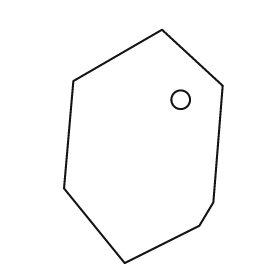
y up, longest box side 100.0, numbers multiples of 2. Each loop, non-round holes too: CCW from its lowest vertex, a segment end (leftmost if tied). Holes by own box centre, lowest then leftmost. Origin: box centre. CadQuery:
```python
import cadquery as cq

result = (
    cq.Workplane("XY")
    .moveTo(-8.0, -50.0)
    .lineTo(24.0, -34.0)
    .lineTo(30.0, -24.0)
    .lineTo(34.0, 26.0)
    .lineTo(8.0, 50.0)
    .lineTo(-30.0, 28.0)
    .lineTo(-34.0, -18.0)
    .close()
    .moveTo(16.0, 20.0)
    .circle(4.0)
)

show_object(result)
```